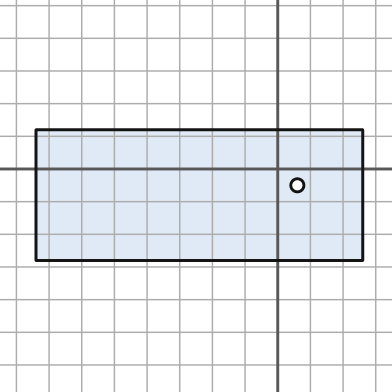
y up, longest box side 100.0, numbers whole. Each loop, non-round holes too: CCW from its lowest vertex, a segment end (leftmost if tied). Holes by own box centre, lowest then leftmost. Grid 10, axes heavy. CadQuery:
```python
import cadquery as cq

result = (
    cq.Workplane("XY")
    .moveTo(-74.0, -28.0)
    .lineTo(26.0, -28.0)
    .lineTo(26.0, 12.0)
    .lineTo(-74.0, 12.0)
    .close()
    .moveTo(6.0, -5.0)
    .circle(2.0)
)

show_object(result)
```